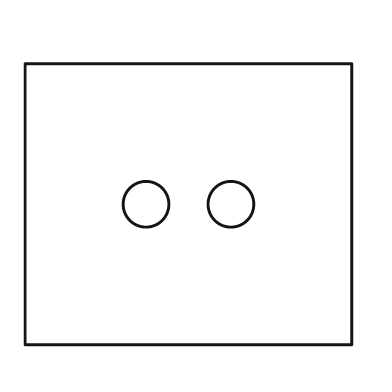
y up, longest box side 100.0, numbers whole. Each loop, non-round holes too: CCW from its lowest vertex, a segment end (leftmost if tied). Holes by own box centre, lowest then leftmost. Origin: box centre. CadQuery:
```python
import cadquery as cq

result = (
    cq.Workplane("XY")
    .moveTo(-50.0, -43.0)
    .lineTo(50.0, -43.0)
    .lineTo(50.0, 43.0)
    .lineTo(-50.0, 43.0)
    .close()
    .moveTo(-13.0, 0.0)
    .circle(7.0)
    .moveTo(13.0, 0.0)
    .circle(7.0)
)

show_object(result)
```